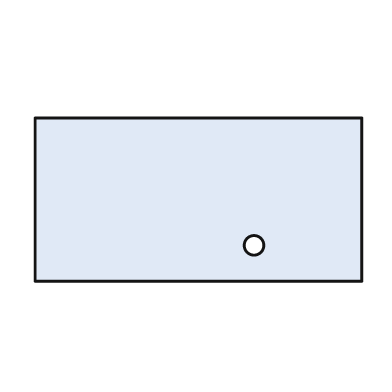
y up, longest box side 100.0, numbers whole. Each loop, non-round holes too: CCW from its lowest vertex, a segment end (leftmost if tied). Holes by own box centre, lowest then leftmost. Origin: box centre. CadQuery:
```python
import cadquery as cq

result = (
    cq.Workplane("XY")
    .moveTo(-50.0, -25.0)
    .lineTo(50.0, -25.0)
    .lineTo(50.0, 25.0)
    .lineTo(-50.0, 25.0)
    .close()
    .moveTo(17.0, -14.0)
    .circle(3.0)
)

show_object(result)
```